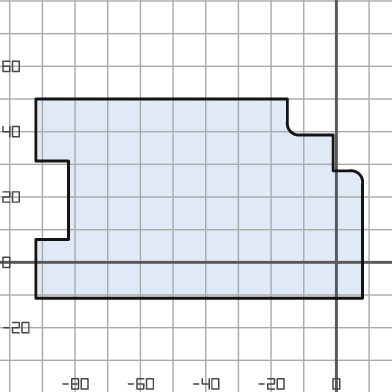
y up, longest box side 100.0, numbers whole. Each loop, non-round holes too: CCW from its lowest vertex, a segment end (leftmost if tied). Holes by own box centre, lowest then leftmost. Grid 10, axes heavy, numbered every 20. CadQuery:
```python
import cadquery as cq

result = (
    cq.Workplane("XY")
    .moveTo(-92.0, -11.0)
    .lineTo(8.0, -11.0)
    .lineTo(8.0, 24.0)
    .threePointArc((7.0, 27.0), (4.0, 28.0))
    .lineTo(-1.0, 28.0)
    .lineTo(-1.0, 39.0)
    .lineTo(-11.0, 39.0)
    .threePointArc((-14.0, 40.0), (-15.0, 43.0))
    .lineTo(-15.0, 50.0)
    .lineTo(-92.0, 50.0)
    .lineTo(-92.0, 31.0)
    .lineTo(-82.0, 31.0)
    .lineTo(-82.0, 7.0)
    .lineTo(-92.0, 7.0)
    .close()
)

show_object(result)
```